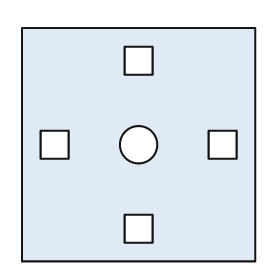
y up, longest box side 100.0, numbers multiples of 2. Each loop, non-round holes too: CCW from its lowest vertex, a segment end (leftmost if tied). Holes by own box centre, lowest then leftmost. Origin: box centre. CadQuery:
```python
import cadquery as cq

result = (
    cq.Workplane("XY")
    .moveTo(-50.0, -50.0)
    .lineTo(50.0, -50.0)
    .lineTo(50.0, 50.0)
    .lineTo(-50.0, 50.0)
    .close()
    .moveTo(-6.0, -42.0)
    .lineTo(6.0, -42.0)
    .lineTo(6.0, -30.0)
    .lineTo(-6.0, -30.0)
    .close()
    .moveTo(-42.0, -6.0)
    .lineTo(-30.0, -6.0)
    .lineTo(-30.0, 6.0)
    .lineTo(-42.0, 6.0)
    .close()
    .moveTo(0.0, 0.0)
    .circle(8.0)
    .moveTo(30.0, -6.0)
    .lineTo(42.0, -6.0)
    .lineTo(42.0, 6.0)
    .lineTo(30.0, 6.0)
    .close()
    .moveTo(-6.0, 30.0)
    .lineTo(6.0, 30.0)
    .lineTo(6.0, 42.0)
    .lineTo(-6.0, 42.0)
    .close()
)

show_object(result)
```